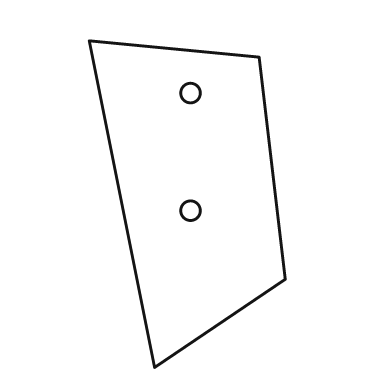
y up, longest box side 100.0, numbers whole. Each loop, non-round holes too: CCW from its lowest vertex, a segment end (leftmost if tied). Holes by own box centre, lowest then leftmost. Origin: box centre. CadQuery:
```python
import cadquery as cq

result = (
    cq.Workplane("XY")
    .moveTo(-10.0, -50.0)
    .lineTo(30.0, -23.0)
    .lineTo(22.0, 45.0)
    .lineTo(-30.0, 50.0)
    .close()
    .moveTo(1.0, -2.0)
    .circle(3.0)
    .moveTo(1.0, 34.0)
    .circle(3.0)
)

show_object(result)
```